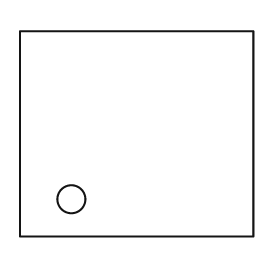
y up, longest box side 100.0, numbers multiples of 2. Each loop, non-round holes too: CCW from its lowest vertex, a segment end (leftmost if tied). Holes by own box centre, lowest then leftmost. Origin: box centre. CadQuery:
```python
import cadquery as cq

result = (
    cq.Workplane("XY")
    .moveTo(-50.0, -44.0)
    .lineTo(50.0, -44.0)
    .lineTo(50.0, 44.0)
    .lineTo(-50.0, 44.0)
    .close()
    .moveTo(-28.0, -28.0)
    .circle(6.0)
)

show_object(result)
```